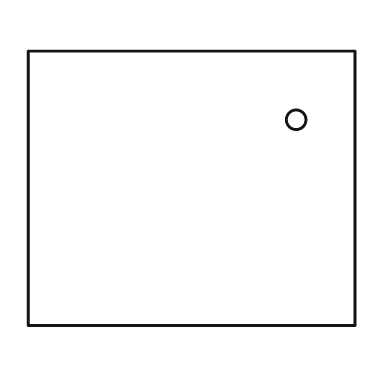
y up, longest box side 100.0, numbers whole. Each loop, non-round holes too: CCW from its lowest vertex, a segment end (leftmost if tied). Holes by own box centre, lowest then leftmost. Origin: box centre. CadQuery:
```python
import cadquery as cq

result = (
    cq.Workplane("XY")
    .moveTo(-50.0, -42.0)
    .lineTo(50.0, -42.0)
    .lineTo(50.0, 42.0)
    .lineTo(-50.0, 42.0)
    .close()
    .moveTo(32.0, 21.0)
    .circle(3.0)
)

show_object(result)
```